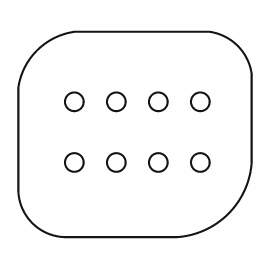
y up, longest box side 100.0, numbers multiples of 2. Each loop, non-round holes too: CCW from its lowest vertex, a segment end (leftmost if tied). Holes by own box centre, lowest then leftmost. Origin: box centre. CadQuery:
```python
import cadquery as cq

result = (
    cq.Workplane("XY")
    .moveTo(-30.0, -44.0)
    .lineTo(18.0, -44.0)
    .threePointArc((40.0, -34.0), (50.0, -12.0))
    .lineTo(50.0, 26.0)
    .threePointArc((44.0, 38.0), (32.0, 44.0))
    .lineTo(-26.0, 44.0)
    .threePointArc((-42.0, 36.0), (-50.0, 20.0))
    .lineTo(-50.0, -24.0)
    .threePointArc((-44.0, -38.0), (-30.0, -44.0))
    .close()
    .moveTo(-26.0, -12.0)
    .circle(4.0)
    .moveTo(-8.0, -12.0)
    .circle(4.0)
    .moveTo(10.0, -12.0)
    .circle(4.0)
    .moveTo(28.0, -12.0)
    .circle(4.0)
    .moveTo(-26.0, 14.0)
    .circle(4.0)
    .moveTo(-8.0, 14.0)
    .circle(4.0)
    .moveTo(10.0, 14.0)
    .circle(4.0)
    .moveTo(28.0, 14.0)
    .circle(4.0)
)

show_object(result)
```